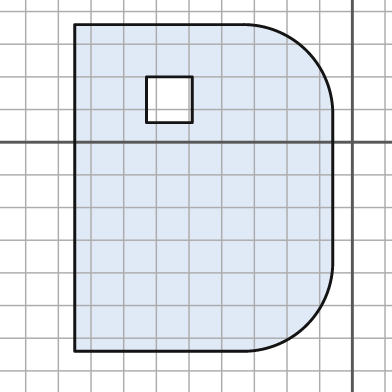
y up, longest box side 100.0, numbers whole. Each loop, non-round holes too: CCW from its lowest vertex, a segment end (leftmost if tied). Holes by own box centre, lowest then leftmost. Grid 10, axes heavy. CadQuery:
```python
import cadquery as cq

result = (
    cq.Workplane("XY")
    .moveTo(-85.0, -64.0)
    .lineTo(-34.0, -64.0)
    .threePointArc((-14.0, -56.0), (-6.0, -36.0))
    .lineTo(-6.0, 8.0)
    .threePointArc((-14.0, 28.0), (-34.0, 36.0))
    .lineTo(-85.0, 36.0)
    .close()
    .moveTo(-63.0, 6.0)
    .lineTo(-49.0, 6.0)
    .lineTo(-49.0, 20.0)
    .lineTo(-63.0, 20.0)
    .close()
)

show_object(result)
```